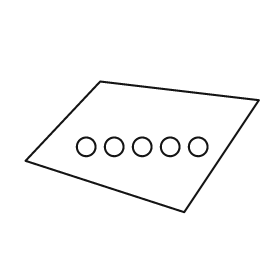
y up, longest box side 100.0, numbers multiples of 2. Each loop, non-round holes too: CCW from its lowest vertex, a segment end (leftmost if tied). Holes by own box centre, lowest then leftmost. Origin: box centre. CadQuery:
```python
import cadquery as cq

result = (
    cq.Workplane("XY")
    .moveTo(18.0, -28.0)
    .lineTo(50.0, 20.0)
    .lineTo(-18.0, 28.0)
    .lineTo(-50.0, -6.0)
    .close()
    .moveTo(-24.0, 0.0)
    .circle(4.0)
    .moveTo(-12.0, 0.0)
    .circle(4.0)
    .moveTo(0.0, 0.0)
    .circle(4.0)
    .moveTo(12.0, 0.0)
    .circle(4.0)
    .moveTo(24.0, 0.0)
    .circle(4.0)
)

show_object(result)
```